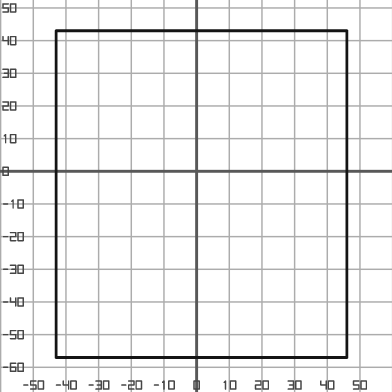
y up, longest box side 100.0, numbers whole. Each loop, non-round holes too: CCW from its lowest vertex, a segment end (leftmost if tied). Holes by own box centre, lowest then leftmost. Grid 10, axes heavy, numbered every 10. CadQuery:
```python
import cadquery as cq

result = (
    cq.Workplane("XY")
    .moveTo(-43.0, -57.0)
    .lineTo(46.0, -57.0)
    .lineTo(46.0, 43.0)
    .lineTo(-43.0, 43.0)
    .close()
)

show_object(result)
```